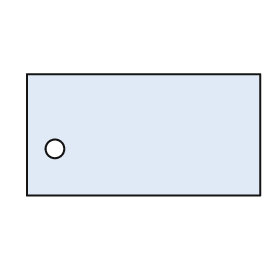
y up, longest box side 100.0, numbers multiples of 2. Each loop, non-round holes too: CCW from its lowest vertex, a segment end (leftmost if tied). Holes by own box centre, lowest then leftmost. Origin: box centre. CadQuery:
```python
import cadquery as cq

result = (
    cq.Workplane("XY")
    .moveTo(-50.0, -26.0)
    .lineTo(50.0, -26.0)
    .lineTo(50.0, 26.0)
    .lineTo(-50.0, 26.0)
    .close()
    .moveTo(-38.0, -6.0)
    .circle(4.0)
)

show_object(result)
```